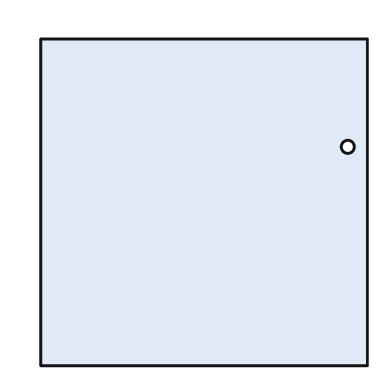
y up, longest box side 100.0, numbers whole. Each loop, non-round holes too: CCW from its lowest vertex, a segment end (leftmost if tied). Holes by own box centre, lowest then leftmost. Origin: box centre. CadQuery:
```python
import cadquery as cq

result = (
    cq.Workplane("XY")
    .moveTo(-50.0, -50.0)
    .lineTo(50.0, -50.0)
    .lineTo(50.0, 50.0)
    .lineTo(-50.0, 50.0)
    .close()
    .moveTo(44.0, 17.0)
    .circle(2.0)
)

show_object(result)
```